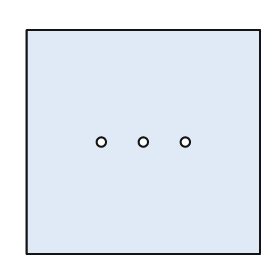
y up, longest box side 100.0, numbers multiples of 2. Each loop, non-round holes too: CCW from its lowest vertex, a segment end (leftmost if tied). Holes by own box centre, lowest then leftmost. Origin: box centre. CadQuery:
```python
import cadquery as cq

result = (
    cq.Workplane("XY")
    .moveTo(-50.0, -48.0)
    .lineTo(50.0, -48.0)
    .lineTo(50.0, 48.0)
    .lineTo(-50.0, 48.0)
    .close()
    .moveTo(-18.0, 0.0)
    .circle(2.0)
    .moveTo(0.0, 0.0)
    .circle(2.0)
    .moveTo(18.0, 0.0)
    .circle(2.0)
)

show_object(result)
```